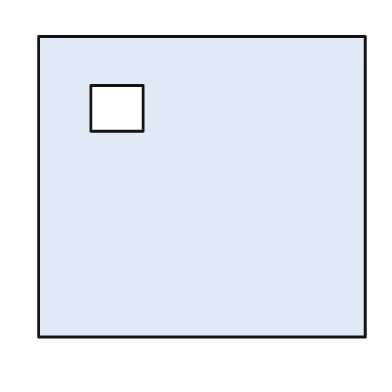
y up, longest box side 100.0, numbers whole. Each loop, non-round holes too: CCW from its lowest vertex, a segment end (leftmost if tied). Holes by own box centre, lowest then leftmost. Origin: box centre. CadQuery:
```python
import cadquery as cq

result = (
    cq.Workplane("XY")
    .moveTo(-50.0, -46.0)
    .lineTo(50.0, -46.0)
    .lineTo(50.0, 46.0)
    .lineTo(-50.0, 46.0)
    .close()
    .moveTo(-34.0, 17.0)
    .lineTo(-18.0, 17.0)
    .lineTo(-18.0, 31.0)
    .lineTo(-34.0, 31.0)
    .close()
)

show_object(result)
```